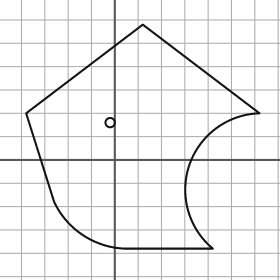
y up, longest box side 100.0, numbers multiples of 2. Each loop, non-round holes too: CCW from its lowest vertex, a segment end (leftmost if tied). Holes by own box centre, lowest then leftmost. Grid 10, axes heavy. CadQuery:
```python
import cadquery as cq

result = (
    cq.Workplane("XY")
    .moveTo(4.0, -38.0)
    .lineTo(42.0, -38.0)
    .threePointArc((32.0, -2.0), (62.0, 20.0))
    .lineTo(12.0, 58.0)
    .lineTo(-38.0, 20.0)
    .lineTo(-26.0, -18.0)
    .threePointArc((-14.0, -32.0), (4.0, -38.0))
    .close()
    .moveTo(-2.0, 16.0)
    .circle(2.0)
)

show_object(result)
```